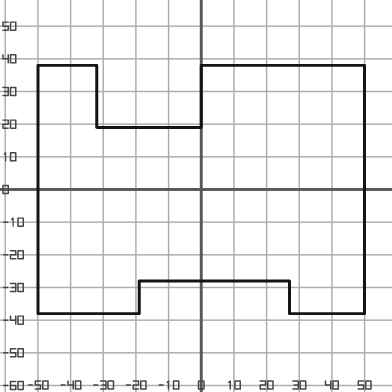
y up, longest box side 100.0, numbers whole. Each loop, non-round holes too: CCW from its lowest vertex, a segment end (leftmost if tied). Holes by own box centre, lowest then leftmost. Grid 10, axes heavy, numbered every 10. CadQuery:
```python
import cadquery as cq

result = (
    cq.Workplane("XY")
    .moveTo(-50.0, -38.0)
    .lineTo(-19.0, -38.0)
    .lineTo(-19.0, -28.0)
    .lineTo(27.0, -28.0)
    .lineTo(27.0, -38.0)
    .lineTo(50.0, -38.0)
    .lineTo(50.0, 38.0)
    .lineTo(0.0, 38.0)
    .lineTo(0.0, 19.0)
    .lineTo(-32.0, 19.0)
    .lineTo(-32.0, 38.0)
    .lineTo(-50.0, 38.0)
    .close()
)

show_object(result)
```